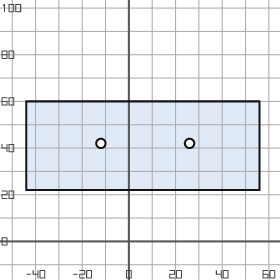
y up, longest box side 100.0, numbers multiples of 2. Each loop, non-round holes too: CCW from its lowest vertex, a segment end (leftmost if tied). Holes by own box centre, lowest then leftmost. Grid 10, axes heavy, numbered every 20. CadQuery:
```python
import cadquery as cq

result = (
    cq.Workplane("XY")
    .moveTo(-44.0, 22.0)
    .lineTo(56.0, 22.0)
    .lineTo(56.0, 60.0)
    .lineTo(-44.0, 60.0)
    .close()
    .moveTo(-12.0, 42.0)
    .circle(2.0)
    .moveTo(26.0, 42.0)
    .circle(2.0)
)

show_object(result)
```